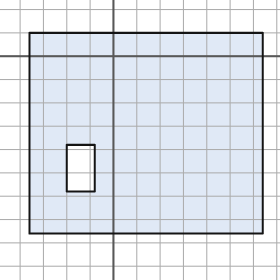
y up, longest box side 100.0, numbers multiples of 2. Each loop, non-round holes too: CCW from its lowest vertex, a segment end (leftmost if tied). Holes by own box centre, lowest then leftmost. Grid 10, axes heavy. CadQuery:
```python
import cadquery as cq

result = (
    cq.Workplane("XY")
    .moveTo(-36.0, -76.0)
    .lineTo(64.0, -76.0)
    .lineTo(64.0, 10.0)
    .lineTo(-36.0, 10.0)
    .close()
    .moveTo(-20.0, -58.0)
    .lineTo(-8.0, -58.0)
    .lineTo(-8.0, -38.0)
    .lineTo(-20.0, -38.0)
    .close()
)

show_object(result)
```